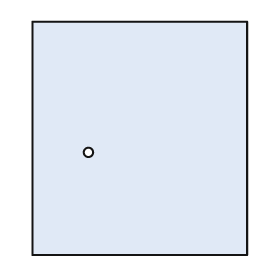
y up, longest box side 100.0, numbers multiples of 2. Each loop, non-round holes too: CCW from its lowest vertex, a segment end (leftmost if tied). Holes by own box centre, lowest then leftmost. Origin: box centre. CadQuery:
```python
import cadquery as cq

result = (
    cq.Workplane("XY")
    .moveTo(-46.0, -50.0)
    .lineTo(46.0, -50.0)
    .lineTo(46.0, 50.0)
    .lineTo(-46.0, 50.0)
    .close()
    .moveTo(-22.0, -6.0)
    .circle(2.0)
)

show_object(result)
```